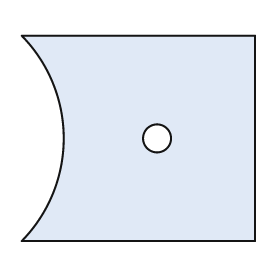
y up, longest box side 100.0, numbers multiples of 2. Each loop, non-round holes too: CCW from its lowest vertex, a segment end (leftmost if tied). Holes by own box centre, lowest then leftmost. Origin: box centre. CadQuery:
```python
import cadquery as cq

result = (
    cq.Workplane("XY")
    .moveTo(-50.0, -44.0)
    .lineTo(50.0, -44.0)
    .lineTo(50.0, 44.0)
    .lineTo(-50.0, 44.0)
    .threePointArc((-32.0, 0.0), (-50.0, -44.0))
    .close()
    .moveTo(8.0, 0.0)
    .circle(6.0)
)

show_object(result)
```